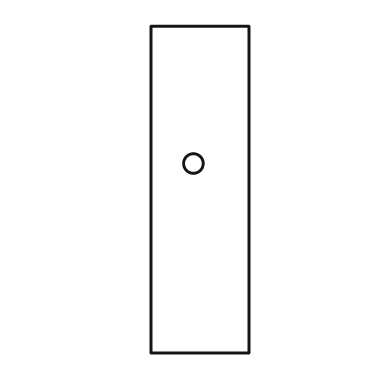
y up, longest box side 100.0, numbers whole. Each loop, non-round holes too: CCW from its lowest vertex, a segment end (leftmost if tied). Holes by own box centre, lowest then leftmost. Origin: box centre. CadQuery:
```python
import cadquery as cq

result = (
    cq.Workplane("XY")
    .moveTo(-15.0, -50.0)
    .lineTo(15.0, -50.0)
    .lineTo(15.0, 50.0)
    .lineTo(-15.0, 50.0)
    .close()
    .moveTo(-2.0, 8.0)
    .circle(3.0)
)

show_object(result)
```